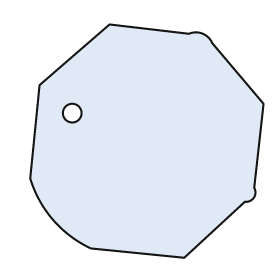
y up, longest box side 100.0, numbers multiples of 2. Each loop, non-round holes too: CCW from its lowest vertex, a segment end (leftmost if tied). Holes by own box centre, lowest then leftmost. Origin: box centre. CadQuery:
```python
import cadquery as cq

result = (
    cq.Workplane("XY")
    .moveTo(16.0, -50.0)
    .lineTo(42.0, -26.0)
    .threePointArc((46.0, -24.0), (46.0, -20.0))
    .lineTo(50.0, 16.0)
    .lineTo(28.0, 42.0)
    .threePointArc((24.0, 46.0), (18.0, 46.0))
    .lineTo(-16.0, 50.0)
    .lineTo(-46.0, 24.0)
    .lineTo(-50.0, -16.0)
    .threePointArc((-40.0, -34.0), (-24.0, -46.0))
    .close()
    .moveTo(-32.0, 12.0)
    .circle(4.0)
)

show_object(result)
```